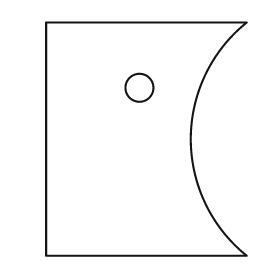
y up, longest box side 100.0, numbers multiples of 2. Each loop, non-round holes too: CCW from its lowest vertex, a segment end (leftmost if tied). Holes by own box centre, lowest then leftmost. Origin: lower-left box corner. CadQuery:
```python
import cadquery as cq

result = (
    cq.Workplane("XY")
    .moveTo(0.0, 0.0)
    .lineTo(86.0, 0.0)
    .threePointArc((62.0, 50.0), (86.0, 100.0))
    .lineTo(0.0, 100.0)
    .close()
    .moveTo(40.0, 72.0)
    .circle(6.0)
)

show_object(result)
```